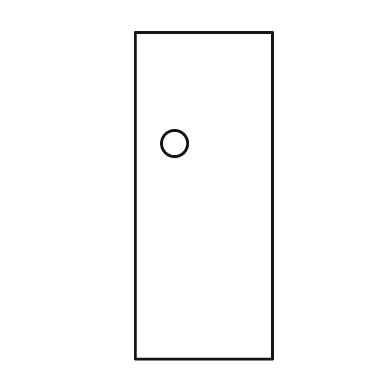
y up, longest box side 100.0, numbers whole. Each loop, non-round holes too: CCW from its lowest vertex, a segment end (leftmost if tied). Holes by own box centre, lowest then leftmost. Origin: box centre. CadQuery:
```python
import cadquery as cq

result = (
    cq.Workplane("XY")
    .moveTo(-21.0, -50.0)
    .lineTo(21.0, -50.0)
    .lineTo(21.0, 50.0)
    .lineTo(-21.0, 50.0)
    .close()
    .moveTo(-9.0, 16.0)
    .circle(4.0)
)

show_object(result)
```